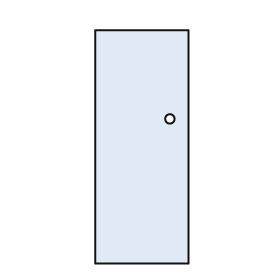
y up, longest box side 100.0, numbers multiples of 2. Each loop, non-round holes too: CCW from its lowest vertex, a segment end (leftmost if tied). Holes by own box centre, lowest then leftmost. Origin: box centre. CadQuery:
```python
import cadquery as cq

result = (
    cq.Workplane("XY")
    .moveTo(-20.0, -50.0)
    .lineTo(20.0, -50.0)
    .lineTo(20.0, 50.0)
    .lineTo(-20.0, 50.0)
    .close()
    .moveTo(12.0, 12.0)
    .circle(2.0)
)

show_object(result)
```